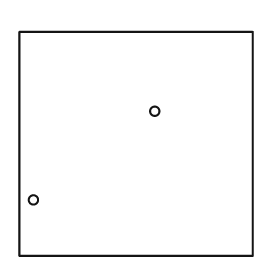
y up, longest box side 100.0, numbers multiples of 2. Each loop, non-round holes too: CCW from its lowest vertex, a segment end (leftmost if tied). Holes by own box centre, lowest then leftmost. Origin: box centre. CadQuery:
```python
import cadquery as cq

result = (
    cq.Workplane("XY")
    .moveTo(-50.0, -48.0)
    .lineTo(50.0, -48.0)
    .lineTo(50.0, 48.0)
    .lineTo(-50.0, 48.0)
    .close()
    .moveTo(-44.0, -24.0)
    .circle(2.0)
    .moveTo(8.0, 14.0)
    .circle(2.0)
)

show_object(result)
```